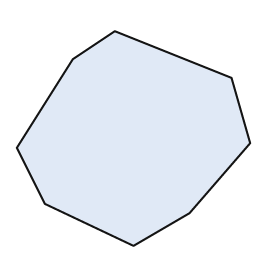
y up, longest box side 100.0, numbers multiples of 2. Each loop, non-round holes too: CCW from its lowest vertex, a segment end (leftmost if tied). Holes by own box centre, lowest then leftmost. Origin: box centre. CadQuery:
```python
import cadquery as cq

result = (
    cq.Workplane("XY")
    .moveTo(0.0, -46.0)
    .lineTo(24.0, -32.0)
    .lineTo(50.0, -2.0)
    .lineTo(42.0, 26.0)
    .lineTo(-8.0, 46.0)
    .lineTo(-26.0, 34.0)
    .lineTo(-50.0, -4.0)
    .lineTo(-38.0, -28.0)
    .close()
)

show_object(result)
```